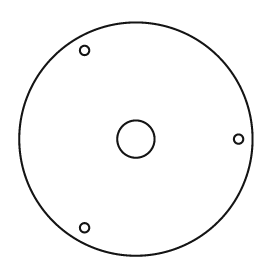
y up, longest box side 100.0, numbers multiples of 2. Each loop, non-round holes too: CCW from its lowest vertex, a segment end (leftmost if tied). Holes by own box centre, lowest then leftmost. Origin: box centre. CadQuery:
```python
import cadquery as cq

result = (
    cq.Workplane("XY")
    .moveTo(0.0, 0.0)
    .circle(50.0)
    .moveTo(-22.0, -38.0)
    .circle(2.0)
    .moveTo(0.0, 0.0)
    .circle(8.0)
    .moveTo(44.0, 0.0)
    .circle(2.0)
    .moveTo(-22.0, 38.0)
    .circle(2.0)
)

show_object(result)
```